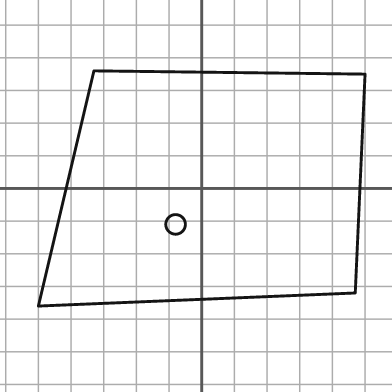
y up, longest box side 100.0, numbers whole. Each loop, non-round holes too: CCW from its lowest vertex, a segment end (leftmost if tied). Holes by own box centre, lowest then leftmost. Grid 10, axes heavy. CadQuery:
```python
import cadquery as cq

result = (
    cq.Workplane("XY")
    .moveTo(-50.0, -36.0)
    .lineTo(47.0, -32.0)
    .lineTo(50.0, 35.0)
    .lineTo(-33.0, 36.0)
    .close()
    .moveTo(-8.0, -11.0)
    .circle(3.0)
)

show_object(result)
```